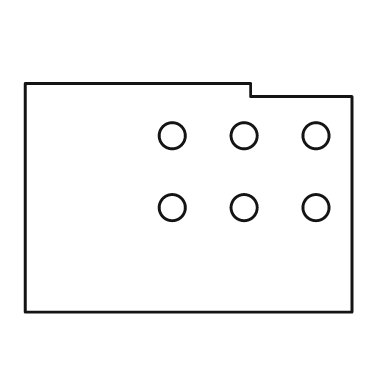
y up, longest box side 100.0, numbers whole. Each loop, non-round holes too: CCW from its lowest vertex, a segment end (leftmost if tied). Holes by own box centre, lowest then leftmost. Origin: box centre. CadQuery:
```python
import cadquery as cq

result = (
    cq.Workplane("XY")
    .moveTo(-50.0, -35.0)
    .lineTo(50.0, -35.0)
    .lineTo(50.0, 31.0)
    .lineTo(19.0, 31.0)
    .lineTo(19.0, 35.0)
    .lineTo(-50.0, 35.0)
    .close()
    .moveTo(-5.0, -3.0)
    .circle(4.0)
    .moveTo(17.0, -3.0)
    .circle(4.0)
    .moveTo(39.0, -3.0)
    .circle(4.0)
    .moveTo(-5.0, 19.0)
    .circle(4.0)
    .moveTo(17.0, 19.0)
    .circle(4.0)
    .moveTo(39.0, 19.0)
    .circle(4.0)
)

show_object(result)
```